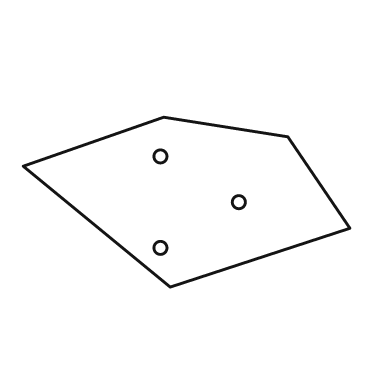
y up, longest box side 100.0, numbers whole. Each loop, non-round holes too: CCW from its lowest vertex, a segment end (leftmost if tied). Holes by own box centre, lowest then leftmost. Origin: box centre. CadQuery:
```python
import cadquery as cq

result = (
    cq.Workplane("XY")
    .moveTo(-5.0, -26.0)
    .lineTo(50.0, -8.0)
    .lineTo(31.0, 20.0)
    .lineTo(-7.0, 26.0)
    .lineTo(-50.0, 11.0)
    .close()
    .moveTo(-8.0, -14.0)
    .circle(2.0)
    .moveTo(16.0, 0.0)
    .circle(2.0)
    .moveTo(-8.0, 14.0)
    .circle(2.0)
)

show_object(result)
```